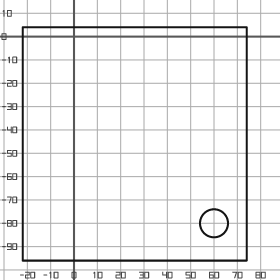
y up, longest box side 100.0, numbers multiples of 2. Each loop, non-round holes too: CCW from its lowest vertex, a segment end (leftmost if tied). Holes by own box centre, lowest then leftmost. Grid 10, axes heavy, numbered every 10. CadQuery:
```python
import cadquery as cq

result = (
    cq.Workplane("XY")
    .moveTo(-22.0, -96.0)
    .lineTo(74.0, -96.0)
    .lineTo(74.0, 4.0)
    .lineTo(-22.0, 4.0)
    .close()
    .moveTo(60.0, -80.0)
    .circle(6.0)
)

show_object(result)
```